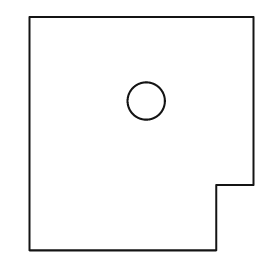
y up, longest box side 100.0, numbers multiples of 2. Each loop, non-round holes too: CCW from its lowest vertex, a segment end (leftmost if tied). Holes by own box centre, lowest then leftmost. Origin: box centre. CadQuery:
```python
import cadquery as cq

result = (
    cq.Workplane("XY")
    .moveTo(-48.0, -50.0)
    .lineTo(32.0, -50.0)
    .lineTo(32.0, -22.0)
    .lineTo(48.0, -22.0)
    .lineTo(48.0, 50.0)
    .lineTo(-48.0, 50.0)
    .close()
    .moveTo(2.0, 14.0)
    .circle(8.0)
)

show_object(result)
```